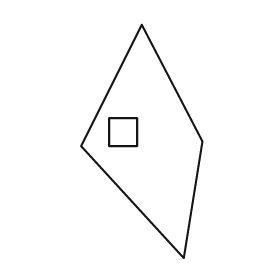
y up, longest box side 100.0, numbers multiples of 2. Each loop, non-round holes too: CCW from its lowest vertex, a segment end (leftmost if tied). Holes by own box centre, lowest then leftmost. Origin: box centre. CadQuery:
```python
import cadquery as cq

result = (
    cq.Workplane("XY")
    .moveTo(18.0, -50.0)
    .lineTo(26.0, 0.0)
    .lineTo(0.0, 50.0)
    .lineTo(-26.0, -2.0)
    .close()
    .moveTo(-14.0, -2.0)
    .lineTo(-2.0, -2.0)
    .lineTo(-2.0, 10.0)
    .lineTo(-14.0, 10.0)
    .close()
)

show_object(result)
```